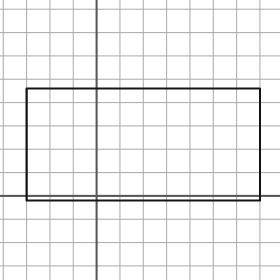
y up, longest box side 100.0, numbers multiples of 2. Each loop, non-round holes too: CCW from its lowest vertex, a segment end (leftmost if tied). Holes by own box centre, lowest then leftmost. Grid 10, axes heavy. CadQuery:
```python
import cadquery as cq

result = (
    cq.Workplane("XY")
    .moveTo(-30.0, -2.0)
    .lineTo(70.0, -2.0)
    .lineTo(70.0, 46.0)
    .lineTo(-30.0, 46.0)
    .close()
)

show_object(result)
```